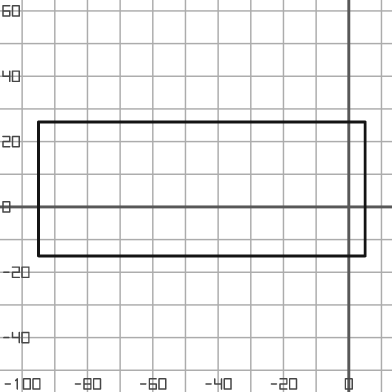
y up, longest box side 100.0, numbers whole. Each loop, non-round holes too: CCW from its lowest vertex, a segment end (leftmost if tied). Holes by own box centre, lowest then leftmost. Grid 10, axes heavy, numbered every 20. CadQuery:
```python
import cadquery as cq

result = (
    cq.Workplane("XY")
    .moveTo(-95.0, -15.0)
    .lineTo(5.0, -15.0)
    .lineTo(5.0, 26.0)
    .lineTo(-95.0, 26.0)
    .close()
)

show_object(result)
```